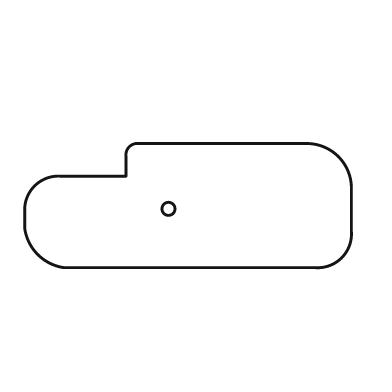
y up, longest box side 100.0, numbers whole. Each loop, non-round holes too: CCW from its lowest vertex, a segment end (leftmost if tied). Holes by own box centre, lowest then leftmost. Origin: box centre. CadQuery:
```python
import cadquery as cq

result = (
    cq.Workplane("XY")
    .moveTo(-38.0, -19.0)
    .lineTo(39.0, -19.0)
    .threePointArc((47.0, -16.0), (50.0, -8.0))
    .lineTo(50.0, 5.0)
    .threePointArc((46.0, 15.0), (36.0, 19.0))
    .lineTo(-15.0, 19.0)
    .threePointArc((-18.0, 18.0), (-19.0, 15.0))
    .lineTo(-19.0, 9.0)
    .lineTo(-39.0, 9.0)
    .threePointArc((-47.0, 6.0), (-50.0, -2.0))
    .lineTo(-50.0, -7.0)
    .threePointArc((-46.0, -15.0), (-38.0, -19.0))
    .close()
    .moveTo(-6.0, -1.0)
    .circle(2.0)
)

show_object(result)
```